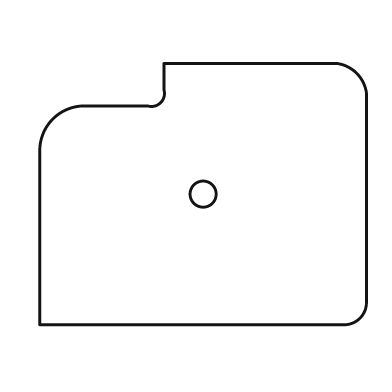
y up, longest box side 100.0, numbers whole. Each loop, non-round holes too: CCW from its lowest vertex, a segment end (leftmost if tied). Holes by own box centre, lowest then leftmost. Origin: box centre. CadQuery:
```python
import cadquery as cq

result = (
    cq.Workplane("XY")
    .moveTo(-50.0, -40.0)
    .lineTo(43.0, -40.0)
    .threePointArc((48.0, -38.0), (50.0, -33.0))
    .lineTo(50.0, 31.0)
    .threePointArc((47.0, 37.0), (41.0, 40.0))
    .lineTo(-12.0, 40.0)
    .lineTo(-12.0, 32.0)
    .threePointArc((-13.0, 28.0), (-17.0, 27.0))
    .lineTo(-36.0, 27.0)
    .threePointArc((-46.0, 23.0), (-50.0, 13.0))
    .close()
    .moveTo(0.0, 0.0)
    .circle(4.0)
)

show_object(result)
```